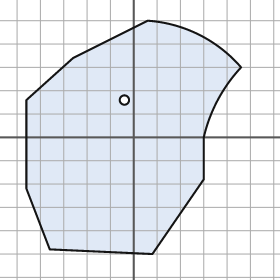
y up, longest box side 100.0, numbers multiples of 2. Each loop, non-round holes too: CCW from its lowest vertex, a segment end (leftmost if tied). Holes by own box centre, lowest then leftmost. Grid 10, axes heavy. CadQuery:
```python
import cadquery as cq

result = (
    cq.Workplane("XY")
    .moveTo(8.0, -50.0)
    .lineTo(30.0, -18.0)
    .lineTo(30.0, 0.0)
    .threePointArc((36.0, 16.0), (46.0, 30.0))
    .threePointArc((28.0, 44.0), (6.0, 50.0))
    .lineTo(-26.0, 34.0)
    .lineTo(-46.0, 16.0)
    .lineTo(-46.0, -22.0)
    .lineTo(-36.0, -48.0)
    .close()
    .moveTo(-4.0, 16.0)
    .circle(2.0)
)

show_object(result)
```